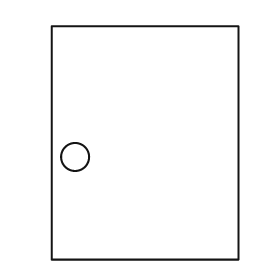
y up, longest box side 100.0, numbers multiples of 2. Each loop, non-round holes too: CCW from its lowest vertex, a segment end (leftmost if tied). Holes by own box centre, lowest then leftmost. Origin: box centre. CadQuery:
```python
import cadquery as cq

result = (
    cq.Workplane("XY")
    .moveTo(-40.0, -50.0)
    .lineTo(40.0, -50.0)
    .lineTo(40.0, 50.0)
    .lineTo(-40.0, 50.0)
    .close()
    .moveTo(-30.0, -6.0)
    .circle(6.0)
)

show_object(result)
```